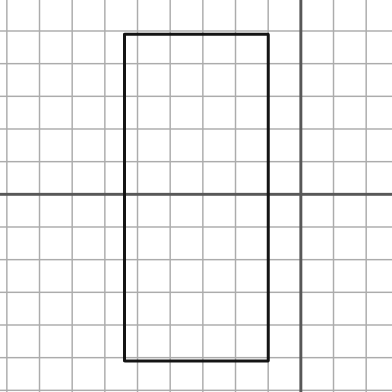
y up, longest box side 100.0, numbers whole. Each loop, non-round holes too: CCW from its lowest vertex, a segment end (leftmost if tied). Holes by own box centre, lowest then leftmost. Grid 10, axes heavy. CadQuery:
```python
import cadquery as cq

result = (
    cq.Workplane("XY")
    .moveTo(-54.0, -51.0)
    .lineTo(-10.0, -51.0)
    .lineTo(-10.0, 49.0)
    .lineTo(-54.0, 49.0)
    .close()
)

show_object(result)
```